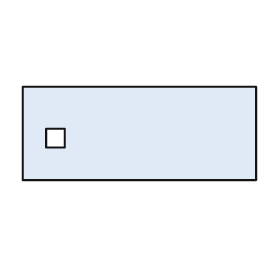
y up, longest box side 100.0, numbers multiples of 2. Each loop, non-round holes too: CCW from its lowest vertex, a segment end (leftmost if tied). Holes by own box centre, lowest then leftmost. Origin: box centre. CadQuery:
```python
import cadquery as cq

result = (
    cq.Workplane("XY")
    .moveTo(-50.0, -20.0)
    .lineTo(50.0, -20.0)
    .lineTo(50.0, 20.0)
    .lineTo(-50.0, 20.0)
    .close()
    .moveTo(-40.0, -6.0)
    .lineTo(-32.0, -6.0)
    .lineTo(-32.0, 2.0)
    .lineTo(-40.0, 2.0)
    .close()
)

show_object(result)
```